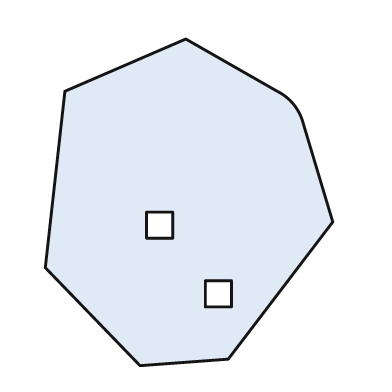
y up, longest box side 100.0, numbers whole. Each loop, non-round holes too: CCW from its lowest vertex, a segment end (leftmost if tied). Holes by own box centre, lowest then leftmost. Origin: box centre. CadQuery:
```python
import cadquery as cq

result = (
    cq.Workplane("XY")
    .moveTo(-15.0, -50.0)
    .lineTo(12.0, -48.0)
    .lineTo(44.0, -6.0)
    .lineTo(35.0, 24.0)
    .threePointArc((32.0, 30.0), (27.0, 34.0))
    .lineTo(-1.0, 50.0)
    .lineTo(-38.0, 34.0)
    .lineTo(-44.0, -20.0)
    .close()
    .moveTo(5.0, -32.0)
    .lineTo(13.0, -32.0)
    .lineTo(13.0, -24.0)
    .lineTo(5.0, -24.0)
    .close()
    .moveTo(-13.0, -11.0)
    .lineTo(-5.0, -11.0)
    .lineTo(-5.0, -3.0)
    .lineTo(-13.0, -3.0)
    .close()
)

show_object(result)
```